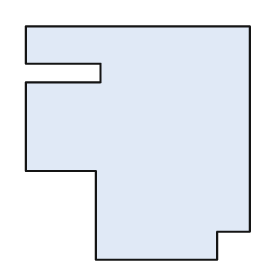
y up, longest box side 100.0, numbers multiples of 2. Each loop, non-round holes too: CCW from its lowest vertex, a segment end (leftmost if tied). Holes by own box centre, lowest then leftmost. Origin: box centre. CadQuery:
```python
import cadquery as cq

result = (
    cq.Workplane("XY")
    .moveTo(-18.0, -50.0)
    .lineTo(34.0, -50.0)
    .lineTo(34.0, -38.0)
    .lineTo(48.0, -38.0)
    .lineTo(48.0, 50.0)
    .lineTo(-48.0, 50.0)
    .lineTo(-48.0, 34.0)
    .lineTo(-16.0, 34.0)
    .lineTo(-16.0, 26.0)
    .lineTo(-48.0, 26.0)
    .lineTo(-48.0, -12.0)
    .lineTo(-18.0, -12.0)
    .close()
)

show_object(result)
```